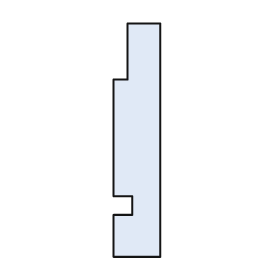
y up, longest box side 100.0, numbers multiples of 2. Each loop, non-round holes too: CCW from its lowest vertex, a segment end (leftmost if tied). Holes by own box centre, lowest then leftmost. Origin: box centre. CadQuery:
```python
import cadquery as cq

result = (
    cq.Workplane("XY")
    .moveTo(-10.0, -50.0)
    .lineTo(10.0, -50.0)
    .lineTo(10.0, 50.0)
    .lineTo(-4.0, 50.0)
    .lineTo(-4.0, 26.0)
    .lineTo(-10.0, 26.0)
    .lineTo(-10.0, -24.0)
    .lineTo(-2.0, -24.0)
    .lineTo(-2.0, -32.0)
    .lineTo(-10.0, -32.0)
    .close()
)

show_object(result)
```